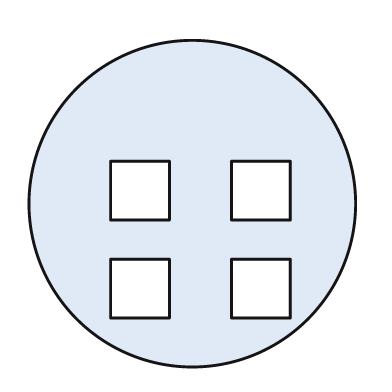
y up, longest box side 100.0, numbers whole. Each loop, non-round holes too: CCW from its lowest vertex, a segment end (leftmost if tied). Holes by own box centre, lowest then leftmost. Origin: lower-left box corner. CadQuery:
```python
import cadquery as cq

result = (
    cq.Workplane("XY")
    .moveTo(50.0, 50.0)
    .circle(50.0)
    .moveTo(25.0, 15.0)
    .lineTo(43.0, 15.0)
    .lineTo(43.0, 33.0)
    .lineTo(25.0, 33.0)
    .close()
    .moveTo(62.0, 15.0)
    .lineTo(80.0, 15.0)
    .lineTo(80.0, 33.0)
    .lineTo(62.0, 33.0)
    .close()
    .moveTo(25.0, 45.0)
    .lineTo(43.0, 45.0)
    .lineTo(43.0, 63.0)
    .lineTo(25.0, 63.0)
    .close()
    .moveTo(62.0, 45.0)
    .lineTo(80.0, 45.0)
    .lineTo(80.0, 63.0)
    .lineTo(62.0, 63.0)
    .close()
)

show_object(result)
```